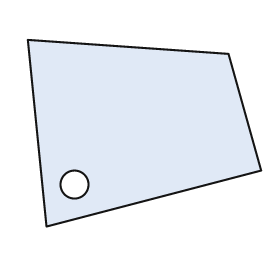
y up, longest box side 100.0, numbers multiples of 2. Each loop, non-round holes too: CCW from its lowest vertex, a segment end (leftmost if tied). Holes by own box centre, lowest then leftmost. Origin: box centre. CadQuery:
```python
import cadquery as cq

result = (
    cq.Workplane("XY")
    .moveTo(-42.0, -40.0)
    .lineTo(50.0, -16.0)
    .lineTo(36.0, 34.0)
    .lineTo(-50.0, 40.0)
    .close()
    .moveTo(-30.0, -22.0)
    .circle(6.0)
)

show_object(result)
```